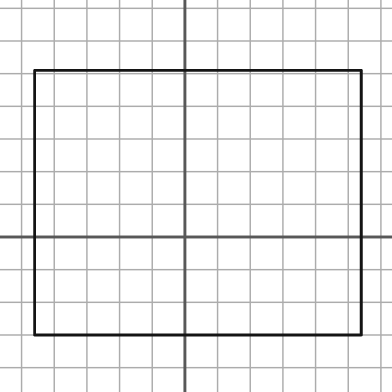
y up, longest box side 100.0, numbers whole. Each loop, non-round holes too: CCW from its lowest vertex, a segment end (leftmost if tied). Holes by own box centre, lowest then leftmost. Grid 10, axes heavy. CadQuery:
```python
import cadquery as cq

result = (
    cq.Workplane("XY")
    .moveTo(-46.0, -30.0)
    .lineTo(54.0, -30.0)
    .lineTo(54.0, 51.0)
    .lineTo(-46.0, 51.0)
    .close()
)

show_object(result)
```